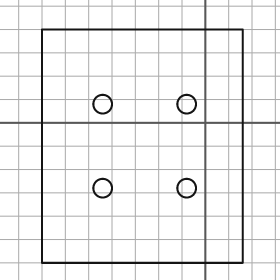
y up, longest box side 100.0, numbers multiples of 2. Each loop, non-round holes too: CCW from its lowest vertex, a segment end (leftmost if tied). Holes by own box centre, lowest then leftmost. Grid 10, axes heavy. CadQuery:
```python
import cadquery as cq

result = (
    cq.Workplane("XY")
    .moveTo(-70.0, -60.0)
    .lineTo(16.0, -60.0)
    .lineTo(16.0, 40.0)
    .lineTo(-70.0, 40.0)
    .close()
    .moveTo(-44.0, -28.0)
    .circle(4.0)
    .moveTo(-8.0, -28.0)
    .circle(4.0)
    .moveTo(-44.0, 8.0)
    .circle(4.0)
    .moveTo(-8.0, 8.0)
    .circle(4.0)
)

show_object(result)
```